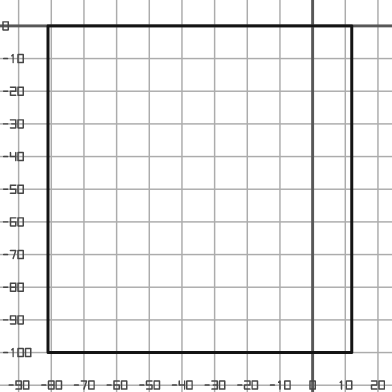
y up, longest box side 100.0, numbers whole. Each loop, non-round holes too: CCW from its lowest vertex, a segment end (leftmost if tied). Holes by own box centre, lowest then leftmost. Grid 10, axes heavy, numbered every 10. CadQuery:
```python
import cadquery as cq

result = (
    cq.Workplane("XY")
    .moveTo(-81.0, -100.0)
    .lineTo(12.0, -100.0)
    .lineTo(12.0, 0.0)
    .lineTo(-81.0, 0.0)
    .close()
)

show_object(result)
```